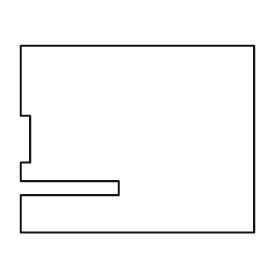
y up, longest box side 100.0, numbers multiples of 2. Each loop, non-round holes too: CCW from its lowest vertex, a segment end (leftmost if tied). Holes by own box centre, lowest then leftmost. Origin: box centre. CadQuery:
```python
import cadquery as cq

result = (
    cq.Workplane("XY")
    .moveTo(-50.0, -40.0)
    .lineTo(50.0, -40.0)
    .lineTo(50.0, 40.0)
    .lineTo(-50.0, 40.0)
    .lineTo(-50.0, 10.0)
    .lineTo(-46.0, 10.0)
    .lineTo(-46.0, -10.0)
    .lineTo(-50.0, -10.0)
    .lineTo(-50.0, -18.0)
    .lineTo(-8.0, -18.0)
    .lineTo(-8.0, -24.0)
    .lineTo(-50.0, -24.0)
    .close()
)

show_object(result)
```